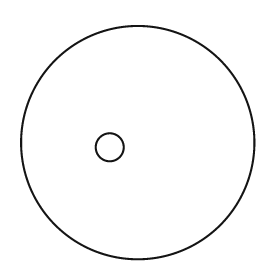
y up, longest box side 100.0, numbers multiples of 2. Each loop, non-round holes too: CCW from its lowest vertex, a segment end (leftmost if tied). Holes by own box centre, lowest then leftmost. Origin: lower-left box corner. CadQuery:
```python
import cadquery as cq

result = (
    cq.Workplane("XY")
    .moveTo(50.0, 50.0)
    .circle(50.0)
    .moveTo(38.0, 48.0)
    .circle(6.0)
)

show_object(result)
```